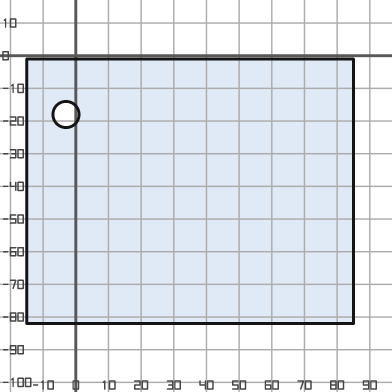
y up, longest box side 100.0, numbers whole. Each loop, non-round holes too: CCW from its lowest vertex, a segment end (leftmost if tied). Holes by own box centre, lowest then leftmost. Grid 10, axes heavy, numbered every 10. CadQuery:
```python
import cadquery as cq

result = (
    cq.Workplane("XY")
    .moveTo(-15.0, -82.0)
    .lineTo(85.0, -82.0)
    .lineTo(85.0, -1.0)
    .lineTo(-15.0, -1.0)
    .close()
    .moveTo(-3.0, -18.0)
    .circle(4.0)
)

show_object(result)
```